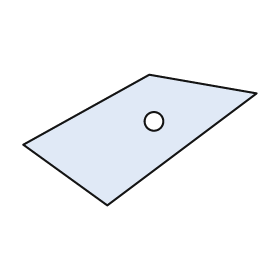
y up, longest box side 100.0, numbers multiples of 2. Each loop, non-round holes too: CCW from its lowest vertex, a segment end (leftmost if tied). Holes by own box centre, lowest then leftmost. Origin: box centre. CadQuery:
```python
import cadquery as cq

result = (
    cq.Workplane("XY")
    .moveTo(-14.0, -28.0)
    .lineTo(50.0, 20.0)
    .lineTo(4.0, 28.0)
    .lineTo(-50.0, -2.0)
    .close()
    .moveTo(6.0, 8.0)
    .circle(4.0)
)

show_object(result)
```